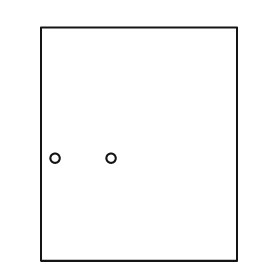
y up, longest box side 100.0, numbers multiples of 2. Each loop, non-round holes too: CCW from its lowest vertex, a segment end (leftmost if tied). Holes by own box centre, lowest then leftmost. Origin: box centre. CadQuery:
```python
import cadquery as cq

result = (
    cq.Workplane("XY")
    .moveTo(-42.0, -50.0)
    .lineTo(42.0, -50.0)
    .lineTo(42.0, 50.0)
    .lineTo(-42.0, 50.0)
    .close()
    .moveTo(-36.0, -6.0)
    .circle(2.0)
    .moveTo(-12.0, -6.0)
    .circle(2.0)
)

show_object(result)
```